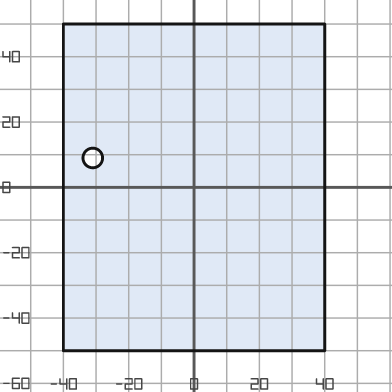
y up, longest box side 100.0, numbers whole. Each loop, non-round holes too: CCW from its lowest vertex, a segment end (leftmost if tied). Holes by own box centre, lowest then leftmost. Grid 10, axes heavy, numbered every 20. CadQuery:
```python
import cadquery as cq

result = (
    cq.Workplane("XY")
    .moveTo(-40.0, -50.0)
    .lineTo(40.0, -50.0)
    .lineTo(40.0, 50.0)
    .lineTo(-40.0, 50.0)
    .close()
    .moveTo(-31.0, 9.0)
    .circle(3.0)
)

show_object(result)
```